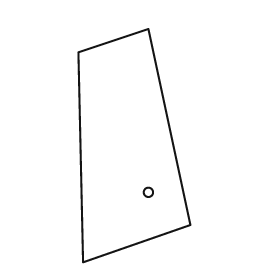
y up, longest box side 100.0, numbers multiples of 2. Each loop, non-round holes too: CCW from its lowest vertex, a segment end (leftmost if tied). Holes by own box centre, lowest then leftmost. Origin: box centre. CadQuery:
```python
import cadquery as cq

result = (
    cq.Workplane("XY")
    .moveTo(-22.0, -50.0)
    .lineTo(24.0, -34.0)
    .lineTo(6.0, 50.0)
    .lineTo(-24.0, 40.0)
    .close()
    .moveTo(6.0, -20.0)
    .circle(2.0)
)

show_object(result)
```